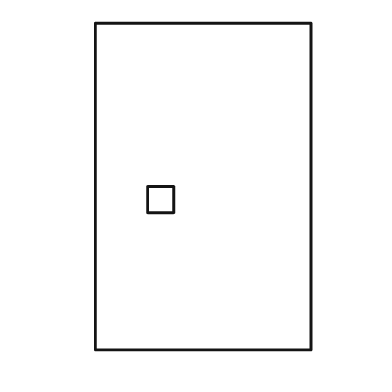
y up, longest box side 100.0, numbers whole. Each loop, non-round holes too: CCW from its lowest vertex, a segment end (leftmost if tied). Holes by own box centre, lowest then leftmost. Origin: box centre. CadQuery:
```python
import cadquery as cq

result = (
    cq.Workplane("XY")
    .moveTo(-33.0, -50.0)
    .lineTo(33.0, -50.0)
    .lineTo(33.0, 50.0)
    .lineTo(-33.0, 50.0)
    .close()
    .moveTo(-17.0, -8.0)
    .lineTo(-9.0, -8.0)
    .lineTo(-9.0, 0.0)
    .lineTo(-17.0, 0.0)
    .close()
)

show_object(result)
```